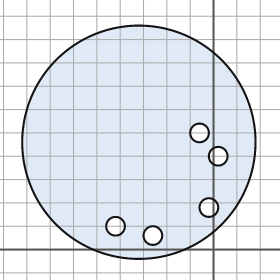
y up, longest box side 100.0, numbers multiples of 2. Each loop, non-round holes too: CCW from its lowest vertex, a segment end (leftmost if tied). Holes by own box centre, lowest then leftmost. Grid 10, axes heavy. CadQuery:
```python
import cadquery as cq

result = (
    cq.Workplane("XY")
    .moveTo(-32.0, 46.0)
    .circle(50.0)
    .moveTo(-26.0, 6.0)
    .circle(4.0)
    .moveTo(-42.0, 10.0)
    .circle(4.0)
    .moveTo(-2.0, 18.0)
    .circle(4.0)
    .moveTo(2.0, 40.0)
    .circle(4.0)
    .moveTo(-6.0, 50.0)
    .circle(4.0)
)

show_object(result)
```